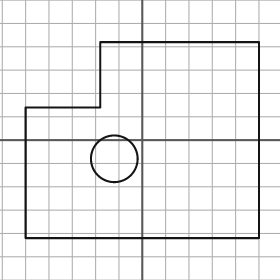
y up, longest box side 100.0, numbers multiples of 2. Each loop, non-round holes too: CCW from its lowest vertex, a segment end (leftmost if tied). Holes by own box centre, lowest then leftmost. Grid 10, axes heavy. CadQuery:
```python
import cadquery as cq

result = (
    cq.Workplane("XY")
    .moveTo(-50.0, -42.0)
    .lineTo(50.0, -42.0)
    .lineTo(50.0, 42.0)
    .lineTo(-18.0, 42.0)
    .lineTo(-18.0, 14.0)
    .lineTo(-50.0, 14.0)
    .close()
    .moveTo(-12.0, -8.0)
    .circle(10.0)
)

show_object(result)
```